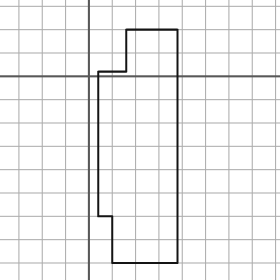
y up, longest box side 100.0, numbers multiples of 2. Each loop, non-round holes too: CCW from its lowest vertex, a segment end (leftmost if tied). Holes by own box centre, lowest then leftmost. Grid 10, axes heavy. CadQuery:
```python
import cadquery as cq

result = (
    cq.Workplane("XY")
    .moveTo(10.0, -80.0)
    .lineTo(38.0, -80.0)
    .lineTo(38.0, 20.0)
    .lineTo(16.0, 20.0)
    .lineTo(16.0, 2.0)
    .lineTo(4.0, 2.0)
    .lineTo(4.0, -60.0)
    .lineTo(10.0, -60.0)
    .close()
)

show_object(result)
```